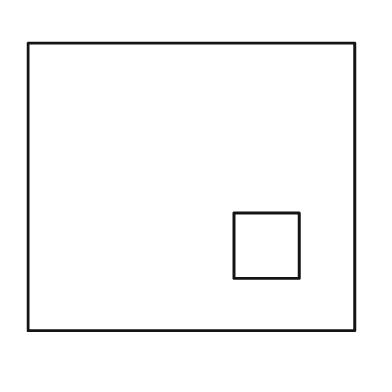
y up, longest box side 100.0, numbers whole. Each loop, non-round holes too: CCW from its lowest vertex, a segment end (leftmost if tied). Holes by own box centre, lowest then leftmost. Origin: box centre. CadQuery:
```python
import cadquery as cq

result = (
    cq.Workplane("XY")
    .moveTo(-50.0, -44.0)
    .lineTo(50.0, -44.0)
    .lineTo(50.0, 44.0)
    .lineTo(-50.0, 44.0)
    .close()
    .moveTo(13.0, -28.0)
    .lineTo(33.0, -28.0)
    .lineTo(33.0, -8.0)
    .lineTo(13.0, -8.0)
    .close()
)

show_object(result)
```